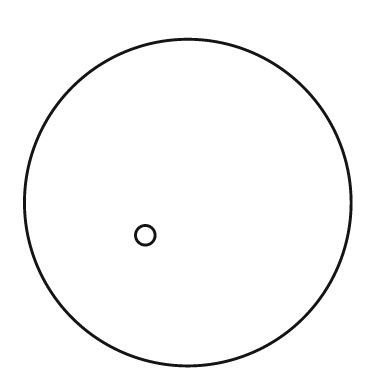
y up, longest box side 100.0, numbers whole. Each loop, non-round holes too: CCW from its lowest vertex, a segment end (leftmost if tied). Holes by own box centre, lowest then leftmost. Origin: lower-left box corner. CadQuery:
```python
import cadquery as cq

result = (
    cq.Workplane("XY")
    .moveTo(50.0, 50.0)
    .circle(50.0)
    .moveTo(37.0, 40.0)
    .circle(3.0)
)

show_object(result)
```